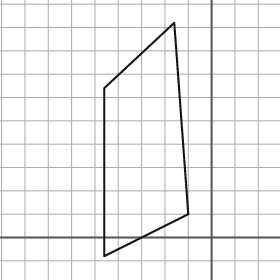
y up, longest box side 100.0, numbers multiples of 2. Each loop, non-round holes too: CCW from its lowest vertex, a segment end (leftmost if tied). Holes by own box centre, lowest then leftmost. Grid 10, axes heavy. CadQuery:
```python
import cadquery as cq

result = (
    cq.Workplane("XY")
    .moveTo(-46.0, -8.0)
    .lineTo(-10.0, 10.0)
    .lineTo(-16.0, 92.0)
    .lineTo(-46.0, 64.0)
    .close()
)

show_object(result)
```